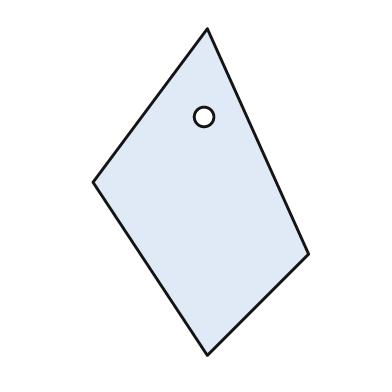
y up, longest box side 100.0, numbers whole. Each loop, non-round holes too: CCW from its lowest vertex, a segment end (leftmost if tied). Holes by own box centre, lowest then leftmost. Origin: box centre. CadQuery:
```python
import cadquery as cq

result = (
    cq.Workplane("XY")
    .moveTo(2.0, -50.0)
    .lineTo(33.0, -19.0)
    .lineTo(2.0, 50.0)
    .lineTo(-33.0, 3.0)
    .close()
    .moveTo(1.0, 23.0)
    .circle(3.0)
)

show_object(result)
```